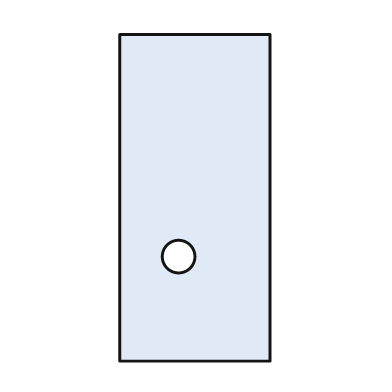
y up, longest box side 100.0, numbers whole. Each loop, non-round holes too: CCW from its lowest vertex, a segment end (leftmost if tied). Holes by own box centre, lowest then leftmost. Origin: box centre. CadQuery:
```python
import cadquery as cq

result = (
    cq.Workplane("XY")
    .moveTo(-23.0, -50.0)
    .lineTo(23.0, -50.0)
    .lineTo(23.0, 50.0)
    .lineTo(-23.0, 50.0)
    .close()
    .moveTo(-5.0, -18.0)
    .circle(5.0)
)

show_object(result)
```